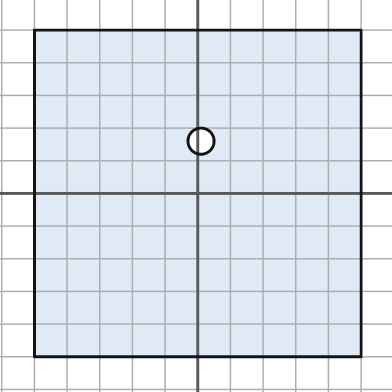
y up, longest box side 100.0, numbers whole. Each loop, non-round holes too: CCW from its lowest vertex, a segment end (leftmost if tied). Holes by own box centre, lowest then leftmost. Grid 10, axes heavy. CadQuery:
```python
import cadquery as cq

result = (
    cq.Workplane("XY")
    .moveTo(-50.0, -50.0)
    .lineTo(50.0, -50.0)
    .lineTo(50.0, 50.0)
    .lineTo(-50.0, 50.0)
    .close()
    .moveTo(1.0, 16.0)
    .circle(4.0)
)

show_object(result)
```